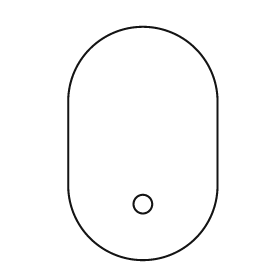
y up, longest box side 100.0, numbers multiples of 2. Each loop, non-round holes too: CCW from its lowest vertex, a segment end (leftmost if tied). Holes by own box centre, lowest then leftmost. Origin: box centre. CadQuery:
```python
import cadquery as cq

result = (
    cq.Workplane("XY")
    .moveTo(-32.0, -18.0)
    .threePointArc((0.0, -50.0), (32.0, -18.0))
    .lineTo(32.0, 18.0)
    .threePointArc((0.0, 50.0), (-32.0, 18.0))
    .close()
    .moveTo(0.0, -26.0)
    .circle(4.0)
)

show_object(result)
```